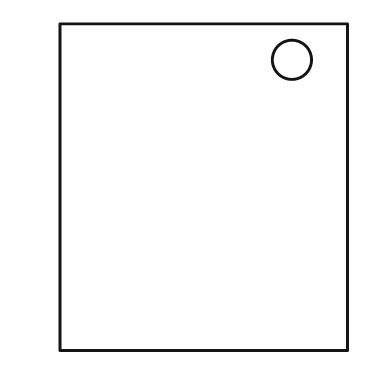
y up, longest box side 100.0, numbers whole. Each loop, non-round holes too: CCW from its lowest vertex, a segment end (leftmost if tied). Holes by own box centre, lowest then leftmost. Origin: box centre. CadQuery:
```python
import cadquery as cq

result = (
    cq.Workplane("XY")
    .moveTo(-44.0, -50.0)
    .lineTo(44.0, -50.0)
    .lineTo(44.0, 50.0)
    .lineTo(-44.0, 50.0)
    .close()
    .moveTo(27.0, 39.0)
    .circle(6.0)
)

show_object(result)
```